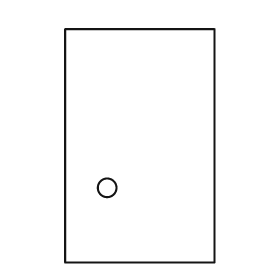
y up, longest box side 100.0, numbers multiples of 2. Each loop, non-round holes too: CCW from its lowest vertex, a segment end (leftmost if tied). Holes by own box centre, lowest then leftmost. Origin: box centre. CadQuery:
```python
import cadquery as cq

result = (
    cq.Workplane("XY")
    .moveTo(-32.0, -50.0)
    .lineTo(32.0, -50.0)
    .lineTo(32.0, 50.0)
    .lineTo(-32.0, 50.0)
    .close()
    .moveTo(-14.0, -18.0)
    .circle(4.0)
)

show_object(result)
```